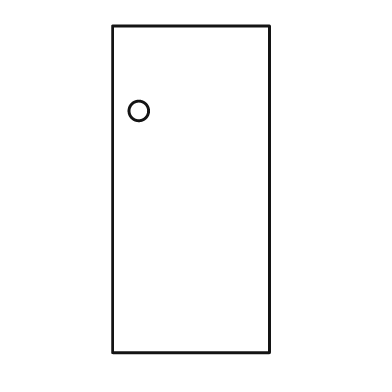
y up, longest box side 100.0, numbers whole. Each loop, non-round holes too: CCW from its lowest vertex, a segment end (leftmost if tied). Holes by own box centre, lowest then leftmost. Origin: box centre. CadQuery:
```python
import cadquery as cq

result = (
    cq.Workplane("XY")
    .moveTo(-24.0, -50.0)
    .lineTo(24.0, -50.0)
    .lineTo(24.0, 50.0)
    .lineTo(-24.0, 50.0)
    .close()
    .moveTo(-16.0, 24.0)
    .circle(3.0)
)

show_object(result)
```